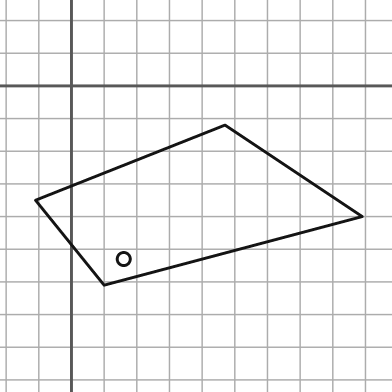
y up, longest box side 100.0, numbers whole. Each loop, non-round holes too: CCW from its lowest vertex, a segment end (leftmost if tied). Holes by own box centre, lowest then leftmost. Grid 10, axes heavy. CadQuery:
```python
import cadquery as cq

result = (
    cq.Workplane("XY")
    .moveTo(10.0, -61.0)
    .lineTo(89.0, -40.0)
    .lineTo(47.0, -12.0)
    .lineTo(-11.0, -35.0)
    .close()
    .moveTo(16.0, -53.0)
    .circle(2.0)
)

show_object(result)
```